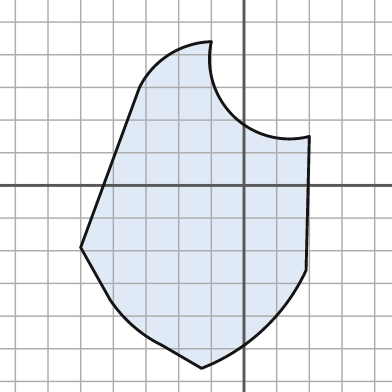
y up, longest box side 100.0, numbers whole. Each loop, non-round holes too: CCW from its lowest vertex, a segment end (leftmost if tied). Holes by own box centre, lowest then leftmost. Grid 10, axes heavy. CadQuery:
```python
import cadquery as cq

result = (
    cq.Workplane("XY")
    .moveTo(-13.0, -56.0)
    .threePointArc((6.0, -44.0), (19.0, -26.0))
    .lineTo(20.0, 15.0)
    .threePointArc((-3.0, 21.0), (-10.0, 44.0))
    .threePointArc((-23.0, 40.0), (-32.0, 30.0))
    .lineTo(-50.0, -19.0)
    .lineTo(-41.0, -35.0)
    .threePointArc((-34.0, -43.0), (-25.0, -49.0))
    .close()
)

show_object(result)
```